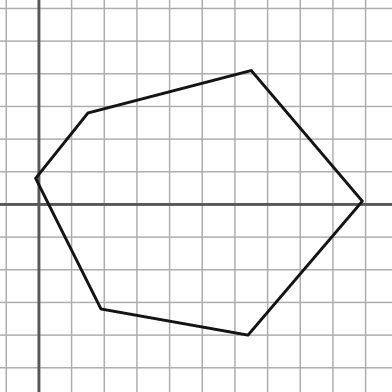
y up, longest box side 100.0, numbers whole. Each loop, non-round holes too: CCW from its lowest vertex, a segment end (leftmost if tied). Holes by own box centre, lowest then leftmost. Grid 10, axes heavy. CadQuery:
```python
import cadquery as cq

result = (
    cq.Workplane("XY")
    .moveTo(64.0, -40.0)
    .lineTo(99.0, 1.0)
    .lineTo(65.0, 41.0)
    .lineTo(15.0, 28.0)
    .lineTo(-1.0, 8.0)
    .lineTo(19.0, -32.0)
    .close()
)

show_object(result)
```